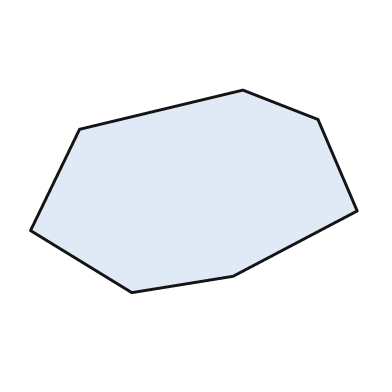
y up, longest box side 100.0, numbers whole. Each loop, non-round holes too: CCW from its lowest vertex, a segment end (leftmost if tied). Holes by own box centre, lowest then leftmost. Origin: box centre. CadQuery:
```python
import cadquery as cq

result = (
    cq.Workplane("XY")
    .moveTo(-19.0, -31.0)
    .lineTo(12.0, -26.0)
    .lineTo(50.0, -6.0)
    .lineTo(38.0, 22.0)
    .lineTo(15.0, 31.0)
    .lineTo(-35.0, 19.0)
    .lineTo(-50.0, -12.0)
    .close()
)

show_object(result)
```